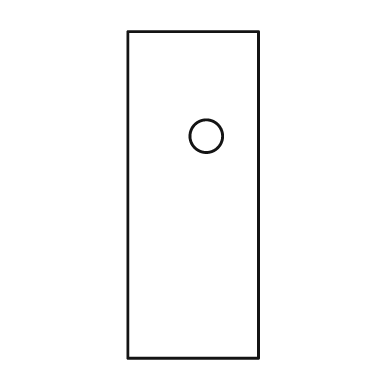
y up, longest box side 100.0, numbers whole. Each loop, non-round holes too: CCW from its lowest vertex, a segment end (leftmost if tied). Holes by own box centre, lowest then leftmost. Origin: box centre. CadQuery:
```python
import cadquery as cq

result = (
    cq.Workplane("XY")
    .moveTo(-20.0, -50.0)
    .lineTo(20.0, -50.0)
    .lineTo(20.0, 50.0)
    .lineTo(-20.0, 50.0)
    .close()
    .moveTo(4.0, 18.0)
    .circle(5.0)
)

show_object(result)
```